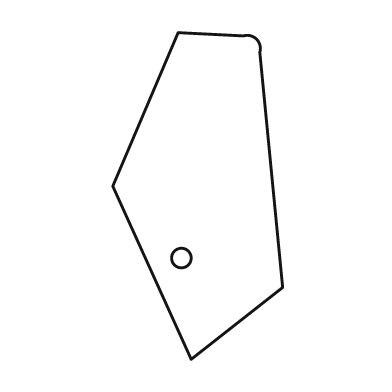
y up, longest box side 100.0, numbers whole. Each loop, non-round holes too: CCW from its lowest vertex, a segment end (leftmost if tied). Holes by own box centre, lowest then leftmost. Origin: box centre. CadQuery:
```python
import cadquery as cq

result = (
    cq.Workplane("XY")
    .moveTo(-2.0, -50.0)
    .lineTo(26.0, -28.0)
    .lineTo(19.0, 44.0)
    .threePointArc((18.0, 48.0), (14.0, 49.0))
    .lineTo(-6.0, 50.0)
    .lineTo(-26.0, 3.0)
    .close()
    .moveTo(-5.0, -19.0)
    .circle(3.0)
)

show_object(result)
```